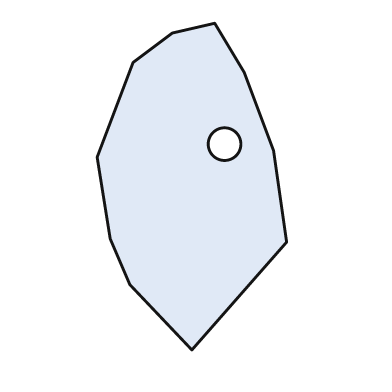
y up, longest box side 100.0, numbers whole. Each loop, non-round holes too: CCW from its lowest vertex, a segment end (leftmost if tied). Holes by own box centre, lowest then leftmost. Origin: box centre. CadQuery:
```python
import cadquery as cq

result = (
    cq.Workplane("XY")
    .moveTo(0.0, -50.0)
    .lineTo(29.0, -17.0)
    .lineTo(25.0, 11.0)
    .lineTo(16.0, 35.0)
    .lineTo(7.0, 50.0)
    .lineTo(-6.0, 47.0)
    .lineTo(-18.0, 38.0)
    .lineTo(-29.0, 9.0)
    .lineTo(-25.0, -16.0)
    .lineTo(-19.0, -30.0)
    .close()
    .moveTo(10.0, 13.0)
    .circle(5.0)
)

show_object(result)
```